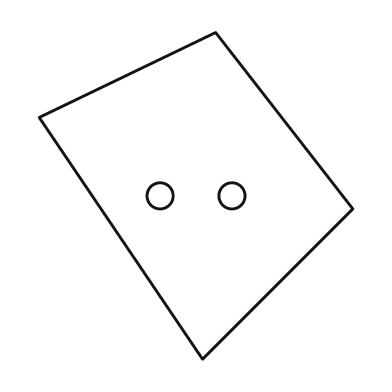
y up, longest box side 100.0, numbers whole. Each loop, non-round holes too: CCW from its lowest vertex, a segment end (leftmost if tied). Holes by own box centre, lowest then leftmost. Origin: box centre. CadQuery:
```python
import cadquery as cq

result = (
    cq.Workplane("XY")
    .moveTo(2.0, -50.0)
    .lineTo(48.0, -4.0)
    .lineTo(6.0, 50.0)
    .lineTo(-48.0, 24.0)
    .close()
    .moveTo(-11.0, 0.0)
    .circle(4.0)
    .moveTo(11.0, 0.0)
    .circle(4.0)
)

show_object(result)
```